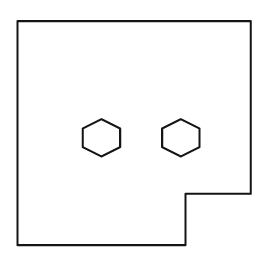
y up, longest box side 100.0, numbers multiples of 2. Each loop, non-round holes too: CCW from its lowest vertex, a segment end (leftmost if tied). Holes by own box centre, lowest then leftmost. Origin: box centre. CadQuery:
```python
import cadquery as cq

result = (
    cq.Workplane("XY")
    .moveTo(-50.0, -48.0)
    .lineTo(22.0, -48.0)
    .lineTo(22.0, -26.0)
    .lineTo(50.0, -26.0)
    .lineTo(50.0, 48.0)
    .lineTo(-50.0, 48.0)
    .close()
    .moveTo(-14.0, -10.0)
    .lineTo(-6.0, -6.0)
    .lineTo(-6.0, 2.0)
    .lineTo(-14.0, 6.0)
    .lineTo(-22.0, 2.0)
    .lineTo(-22.0, -6.0)
    .close()
    .moveTo(20.0, -10.0)
    .lineTo(28.0, -6.0)
    .lineTo(28.0, 2.0)
    .lineTo(20.0, 6.0)
    .lineTo(12.0, 2.0)
    .lineTo(12.0, -6.0)
    .close()
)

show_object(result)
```